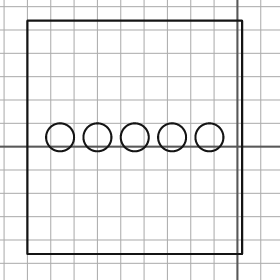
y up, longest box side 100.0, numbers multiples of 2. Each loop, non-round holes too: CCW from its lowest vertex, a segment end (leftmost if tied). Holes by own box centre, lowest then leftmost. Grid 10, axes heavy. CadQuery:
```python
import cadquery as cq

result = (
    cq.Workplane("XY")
    .moveTo(-90.0, -46.0)
    .lineTo(2.0, -46.0)
    .lineTo(2.0, 54.0)
    .lineTo(-90.0, 54.0)
    .close()
    .moveTo(-76.0, 4.0)
    .circle(6.0)
    .moveTo(-60.0, 4.0)
    .circle(6.0)
    .moveTo(-44.0, 4.0)
    .circle(6.0)
    .moveTo(-28.0, 4.0)
    .circle(6.0)
    .moveTo(-12.0, 4.0)
    .circle(6.0)
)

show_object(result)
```